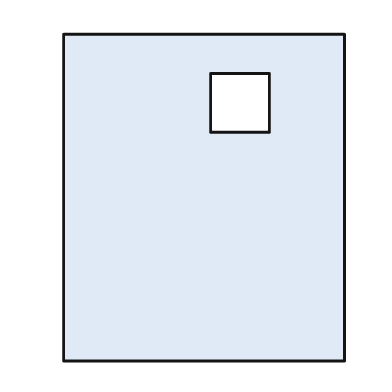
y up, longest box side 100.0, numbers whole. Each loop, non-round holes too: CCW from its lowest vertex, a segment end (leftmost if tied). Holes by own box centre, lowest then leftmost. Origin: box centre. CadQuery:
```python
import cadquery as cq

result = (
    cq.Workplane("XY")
    .moveTo(-43.0, -50.0)
    .lineTo(43.0, -50.0)
    .lineTo(43.0, 50.0)
    .lineTo(-43.0, 50.0)
    .close()
    .moveTo(2.0, 20.0)
    .lineTo(20.0, 20.0)
    .lineTo(20.0, 38.0)
    .lineTo(2.0, 38.0)
    .close()
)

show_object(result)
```